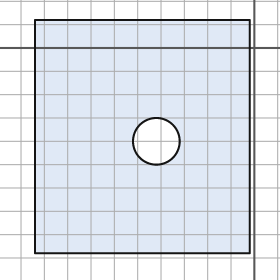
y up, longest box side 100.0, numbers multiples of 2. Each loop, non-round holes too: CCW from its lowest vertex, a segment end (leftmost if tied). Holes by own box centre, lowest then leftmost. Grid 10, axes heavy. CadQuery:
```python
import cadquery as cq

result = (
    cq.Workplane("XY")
    .moveTo(-94.0, -88.0)
    .lineTo(-2.0, -88.0)
    .lineTo(-2.0, 12.0)
    .lineTo(-94.0, 12.0)
    .close()
    .moveTo(-42.0, -40.0)
    .circle(10.0)
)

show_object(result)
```